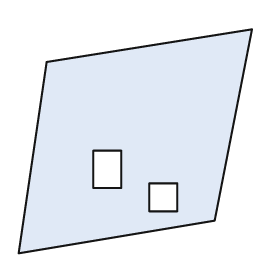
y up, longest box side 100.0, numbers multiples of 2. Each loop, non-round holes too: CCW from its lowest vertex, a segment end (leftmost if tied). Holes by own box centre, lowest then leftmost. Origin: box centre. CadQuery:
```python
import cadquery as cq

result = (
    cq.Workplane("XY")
    .moveTo(-50.0, -48.0)
    .lineTo(34.0, -34.0)
    .lineTo(50.0, 48.0)
    .lineTo(-38.0, 34.0)
    .close()
    .moveTo(6.0, -30.0)
    .lineTo(18.0, -30.0)
    .lineTo(18.0, -18.0)
    .lineTo(6.0, -18.0)
    .close()
    .moveTo(-18.0, -20.0)
    .lineTo(-6.0, -20.0)
    .lineTo(-6.0, -4.0)
    .lineTo(-18.0, -4.0)
    .close()
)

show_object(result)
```